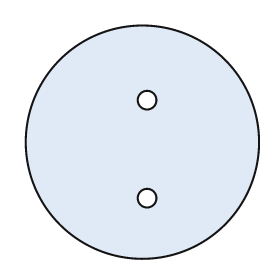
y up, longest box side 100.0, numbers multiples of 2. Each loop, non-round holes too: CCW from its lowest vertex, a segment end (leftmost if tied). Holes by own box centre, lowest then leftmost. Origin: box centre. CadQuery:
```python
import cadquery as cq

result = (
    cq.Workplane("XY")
    .moveTo(0.0, 0.0)
    .circle(50.0)
    .moveTo(2.0, -24.0)
    .circle(4.0)
    .moveTo(2.0, 18.0)
    .circle(4.0)
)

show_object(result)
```